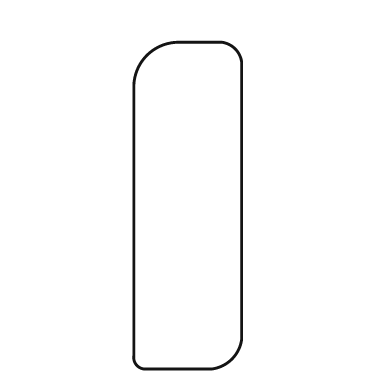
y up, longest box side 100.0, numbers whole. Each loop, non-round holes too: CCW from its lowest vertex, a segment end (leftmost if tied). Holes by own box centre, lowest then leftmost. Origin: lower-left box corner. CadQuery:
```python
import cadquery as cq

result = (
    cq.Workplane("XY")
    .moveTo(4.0, 0.0)
    .lineTo(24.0, 0.0)
    .threePointArc((30.0, 3.0), (33.0, 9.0))
    .lineTo(33.0, 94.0)
    .threePointArc((31.0, 98.0), (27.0, 100.0))
    .lineTo(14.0, 100.0)
    .threePointArc((4.0, 96.0), (0.0, 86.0))
    .lineTo(0.0, 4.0)
    .threePointArc((1.0, 1.0), (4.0, 0.0))
    .close()
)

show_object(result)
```